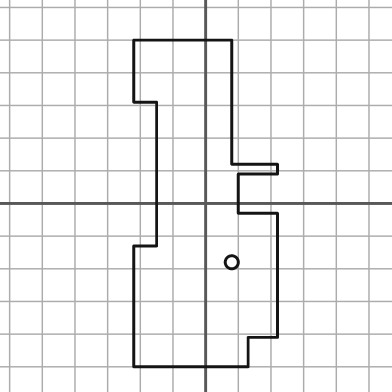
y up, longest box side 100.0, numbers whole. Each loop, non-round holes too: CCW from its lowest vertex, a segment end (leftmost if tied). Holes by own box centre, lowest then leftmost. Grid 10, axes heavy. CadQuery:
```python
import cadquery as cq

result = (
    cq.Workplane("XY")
    .moveTo(-22.0, -50.0)
    .lineTo(13.0, -50.0)
    .lineTo(13.0, -41.0)
    .lineTo(22.0, -41.0)
    .lineTo(22.0, -3.0)
    .lineTo(10.0, -3.0)
    .lineTo(10.0, 9.0)
    .lineTo(22.0, 9.0)
    .lineTo(22.0, 12.0)
    .lineTo(8.0, 12.0)
    .lineTo(8.0, 50.0)
    .lineTo(-22.0, 50.0)
    .lineTo(-22.0, 31.0)
    .lineTo(-15.0, 31.0)
    .lineTo(-15.0, -13.0)
    .lineTo(-22.0, -13.0)
    .close()
    .moveTo(8.0, -18.0)
    .circle(2.0)
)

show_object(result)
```